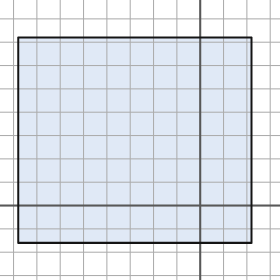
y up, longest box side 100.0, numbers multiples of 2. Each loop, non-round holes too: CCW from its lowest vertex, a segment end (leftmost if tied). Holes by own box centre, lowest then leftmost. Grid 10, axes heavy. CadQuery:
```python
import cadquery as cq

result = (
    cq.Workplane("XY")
    .moveTo(-78.0, -16.0)
    .lineTo(22.0, -16.0)
    .lineTo(22.0, 72.0)
    .lineTo(-78.0, 72.0)
    .close()
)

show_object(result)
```